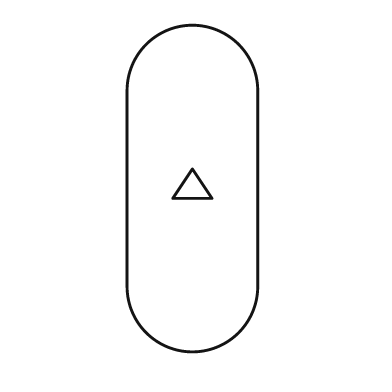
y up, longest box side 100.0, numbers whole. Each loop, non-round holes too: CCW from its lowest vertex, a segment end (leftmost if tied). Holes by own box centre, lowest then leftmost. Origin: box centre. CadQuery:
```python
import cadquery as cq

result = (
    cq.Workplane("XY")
    .moveTo(-20.0, -30.0)
    .threePointArc((0.0, -50.0), (20.0, -30.0))
    .lineTo(20.0, 30.0)
    .threePointArc((0.0, 50.0), (-20.0, 30.0))
    .close()
    .moveTo(-6.0, -3.0)
    .lineTo(6.0, -3.0)
    .lineTo(0.0, 6.0)
    .close()
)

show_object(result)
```